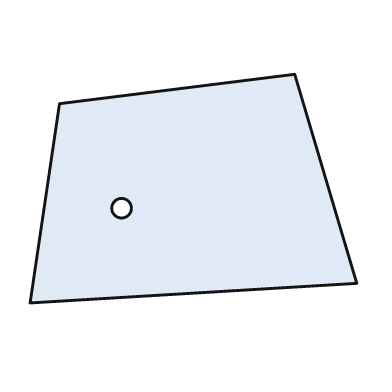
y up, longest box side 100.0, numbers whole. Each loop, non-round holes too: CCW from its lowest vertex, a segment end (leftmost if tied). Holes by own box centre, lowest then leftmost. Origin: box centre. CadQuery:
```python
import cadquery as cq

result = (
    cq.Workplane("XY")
    .moveTo(-50.0, -35.0)
    .lineTo(50.0, -29.0)
    .lineTo(31.0, 35.0)
    .lineTo(-41.0, 26.0)
    .close()
    .moveTo(-22.0, -6.0)
    .circle(3.0)
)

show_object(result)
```